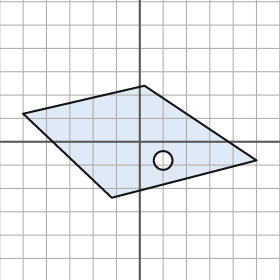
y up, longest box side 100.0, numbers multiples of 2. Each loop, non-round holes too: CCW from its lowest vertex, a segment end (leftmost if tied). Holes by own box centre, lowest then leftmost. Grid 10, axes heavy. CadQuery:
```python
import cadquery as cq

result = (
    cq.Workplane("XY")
    .moveTo(-12.0, -24.0)
    .lineTo(50.0, -8.0)
    .lineTo(2.0, 24.0)
    .lineTo(-50.0, 12.0)
    .close()
    .moveTo(10.0, -8.0)
    .circle(4.0)
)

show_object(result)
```